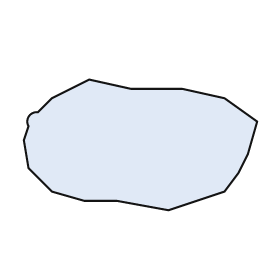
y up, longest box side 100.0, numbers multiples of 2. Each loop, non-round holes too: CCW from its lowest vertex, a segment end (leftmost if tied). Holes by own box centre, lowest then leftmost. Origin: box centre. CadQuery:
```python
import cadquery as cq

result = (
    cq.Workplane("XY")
    .moveTo(12.0, -28.0)
    .lineTo(36.0, -20.0)
    .lineTo(42.0, -12.0)
    .lineTo(46.0, -4.0)
    .lineTo(50.0, 10.0)
    .lineTo(36.0, 20.0)
    .lineTo(18.0, 24.0)
    .lineTo(-4.0, 24.0)
    .lineTo(-22.0, 28.0)
    .lineTo(-38.0, 20.0)
    .lineTo(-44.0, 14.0)
    .threePointArc((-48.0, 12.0), (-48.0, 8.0))
    .lineTo(-50.0, 2.0)
    .lineTo(-48.0, -10.0)
    .lineTo(-38.0, -20.0)
    .lineTo(-24.0, -24.0)
    .lineTo(-10.0, -24.0)
    .close()
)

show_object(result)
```